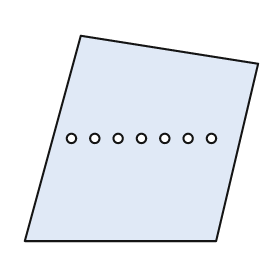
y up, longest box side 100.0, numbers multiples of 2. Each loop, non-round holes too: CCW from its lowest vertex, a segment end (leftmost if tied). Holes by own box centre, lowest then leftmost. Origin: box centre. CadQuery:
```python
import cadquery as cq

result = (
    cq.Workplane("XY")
    .moveTo(-50.0, -44.0)
    .lineTo(32.0, -44.0)
    .lineTo(50.0, 32.0)
    .lineTo(-26.0, 44.0)
    .close()
    .moveTo(-30.0, 0.0)
    .circle(2.0)
    .moveTo(-20.0, 0.0)
    .circle(2.0)
    .moveTo(-10.0, 0.0)
    .circle(2.0)
    .moveTo(0.0, 0.0)
    .circle(2.0)
    .moveTo(10.0, 0.0)
    .circle(2.0)
    .moveTo(20.0, 0.0)
    .circle(2.0)
    .moveTo(30.0, 0.0)
    .circle(2.0)
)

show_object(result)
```